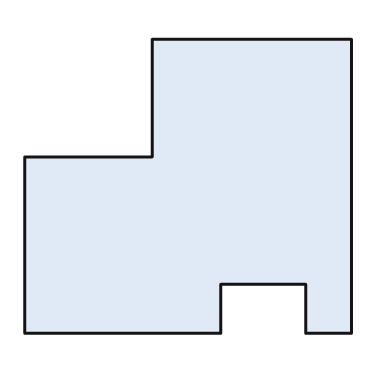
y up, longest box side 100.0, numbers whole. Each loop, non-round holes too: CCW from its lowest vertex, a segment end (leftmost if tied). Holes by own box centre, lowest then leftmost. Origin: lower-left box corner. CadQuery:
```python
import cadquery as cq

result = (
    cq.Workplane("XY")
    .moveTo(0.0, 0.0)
    .lineTo(60.0, 0.0)
    .lineTo(60.0, 15.0)
    .lineTo(86.0, 15.0)
    .lineTo(86.0, 0.0)
    .lineTo(100.0, 0.0)
    .lineTo(100.0, 90.0)
    .lineTo(39.0, 90.0)
    .lineTo(39.0, 54.0)
    .lineTo(0.0, 54.0)
    .close()
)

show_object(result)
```